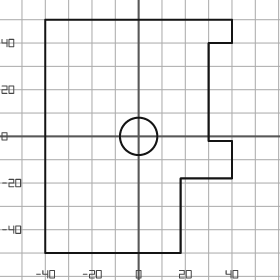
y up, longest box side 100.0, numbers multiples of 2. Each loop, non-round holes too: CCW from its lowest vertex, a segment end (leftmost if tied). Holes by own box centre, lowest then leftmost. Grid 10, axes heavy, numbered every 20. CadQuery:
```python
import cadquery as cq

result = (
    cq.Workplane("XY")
    .moveTo(-40.0, -50.0)
    .lineTo(18.0, -50.0)
    .lineTo(18.0, -18.0)
    .lineTo(40.0, -18.0)
    .lineTo(40.0, -2.0)
    .lineTo(30.0, -2.0)
    .lineTo(30.0, 40.0)
    .lineTo(40.0, 40.0)
    .lineTo(40.0, 50.0)
    .lineTo(-40.0, 50.0)
    .close()
    .moveTo(0.0, 0.0)
    .circle(8.0)
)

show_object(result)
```